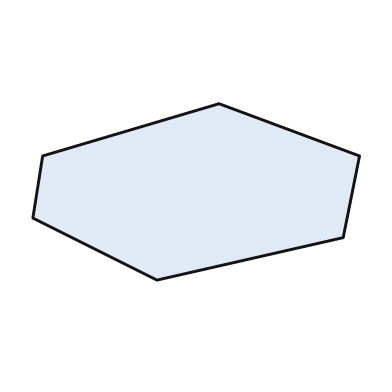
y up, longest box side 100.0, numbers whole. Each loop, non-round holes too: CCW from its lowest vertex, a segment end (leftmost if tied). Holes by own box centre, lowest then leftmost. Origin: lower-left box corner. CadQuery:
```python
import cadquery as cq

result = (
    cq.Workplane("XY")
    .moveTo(38.0, 0.0)
    .lineTo(95.0, 13.0)
    .lineTo(100.0, 38.0)
    .lineTo(57.0, 54.0)
    .lineTo(3.0, 38.0)
    .lineTo(0.0, 19.0)
    .close()
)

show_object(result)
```